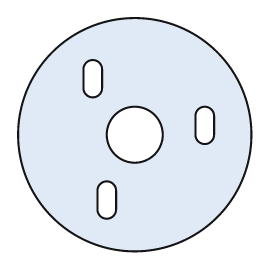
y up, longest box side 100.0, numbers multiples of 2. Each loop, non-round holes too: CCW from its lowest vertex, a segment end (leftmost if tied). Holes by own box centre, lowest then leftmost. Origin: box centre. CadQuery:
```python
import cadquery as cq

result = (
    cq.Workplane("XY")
    .moveTo(0.0, 0.0)
    .circle(50.0)
    .moveTo(-16.0, -32.0)
    .threePointArc((-12.0, -36.0), (-8.0, -32.0))
    .lineTo(-8.0, -24.0)
    .threePointArc((-12.0, -20.0), (-16.0, -24.0))
    .close()
    .moveTo(0.0, 0.0)
    .circle(12.0)
    .moveTo(26.0, 0.0)
    .threePointArc((30.0, -4.0), (34.0, 0.0))
    .lineTo(34.0, 8.0)
    .threePointArc((30.0, 12.0), (26.0, 8.0))
    .close()
    .moveTo(-22.0, 20.0)
    .threePointArc((-18.0, 16.0), (-14.0, 20.0))
    .lineTo(-14.0, 28.0)
    .threePointArc((-18.0, 32.0), (-22.0, 28.0))
    .close()
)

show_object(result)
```